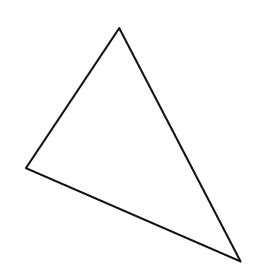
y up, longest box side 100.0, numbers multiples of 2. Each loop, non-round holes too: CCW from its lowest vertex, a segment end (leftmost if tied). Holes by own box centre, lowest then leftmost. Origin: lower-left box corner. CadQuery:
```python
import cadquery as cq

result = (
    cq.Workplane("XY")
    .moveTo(92.0, 0.0)
    .lineTo(40.0, 100.0)
    .lineTo(0.0, 40.0)
    .close()
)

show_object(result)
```